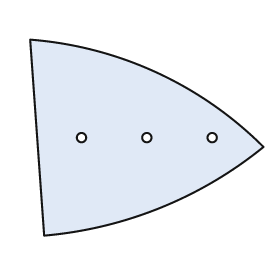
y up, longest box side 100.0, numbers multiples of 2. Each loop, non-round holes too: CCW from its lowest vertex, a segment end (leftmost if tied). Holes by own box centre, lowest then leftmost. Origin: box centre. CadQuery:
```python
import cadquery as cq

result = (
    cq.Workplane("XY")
    .moveTo(-44.0, -42.0)
    .threePointArc((6.0, -30.0), (50.0, -4.0))
    .threePointArc((4.0, 28.0), (-50.0, 42.0))
    .close()
    .moveTo(-28.0, 0.0)
    .circle(2.0)
    .moveTo(0.0, 0.0)
    .circle(2.0)
    .moveTo(28.0, 0.0)
    .circle(2.0)
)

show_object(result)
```